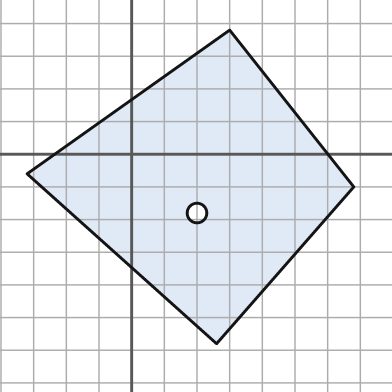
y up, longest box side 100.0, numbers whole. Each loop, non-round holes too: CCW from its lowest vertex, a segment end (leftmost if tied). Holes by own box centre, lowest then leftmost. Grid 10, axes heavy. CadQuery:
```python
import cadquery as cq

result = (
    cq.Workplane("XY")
    .moveTo(26.0, -58.0)
    .lineTo(68.0, -10.0)
    .lineTo(30.0, 38.0)
    .lineTo(-32.0, -6.0)
    .close()
    .moveTo(20.0, -18.0)
    .circle(3.0)
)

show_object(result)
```